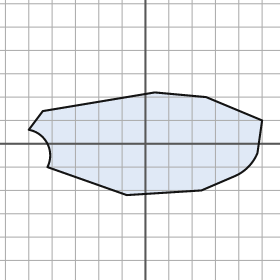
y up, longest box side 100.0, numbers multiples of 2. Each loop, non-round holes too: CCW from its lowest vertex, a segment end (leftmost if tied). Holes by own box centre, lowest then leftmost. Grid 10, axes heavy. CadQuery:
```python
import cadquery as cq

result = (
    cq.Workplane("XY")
    .moveTo(-8.0, -22.0)
    .lineTo(24.0, -20.0)
    .lineTo(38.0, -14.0)
    .threePointArc((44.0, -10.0), (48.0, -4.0))
    .lineTo(50.0, 10.0)
    .lineTo(26.0, 20.0)
    .lineTo(4.0, 22.0)
    .lineTo(-44.0, 14.0)
    .lineTo(-50.0, 6.0)
    .threePointArc((-42.0, 0.0), (-42.0, -10.0))
    .close()
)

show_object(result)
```